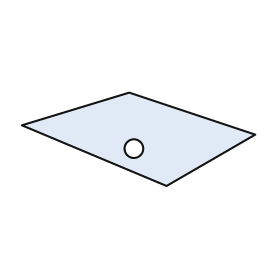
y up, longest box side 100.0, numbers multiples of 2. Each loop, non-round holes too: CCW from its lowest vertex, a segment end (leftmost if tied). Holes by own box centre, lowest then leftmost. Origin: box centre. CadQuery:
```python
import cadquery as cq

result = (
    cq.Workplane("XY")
    .moveTo(12.0, -20.0)
    .lineTo(50.0, 2.0)
    .lineTo(-4.0, 20.0)
    .lineTo(-50.0, 6.0)
    .close()
    .moveTo(-2.0, -4.0)
    .circle(4.0)
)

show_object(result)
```